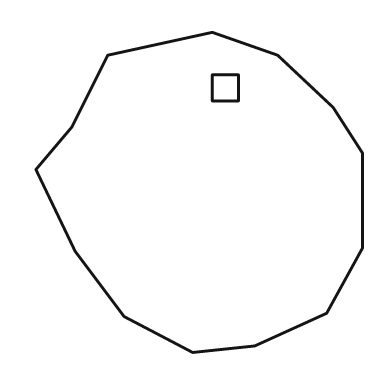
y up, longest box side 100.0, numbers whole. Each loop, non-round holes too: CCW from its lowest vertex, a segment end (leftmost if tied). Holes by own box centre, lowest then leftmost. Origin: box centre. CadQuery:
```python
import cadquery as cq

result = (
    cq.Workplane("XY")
    .moveTo(-2.0, -49.0)
    .lineTo(17.0, -47.0)
    .lineTo(39.0, -37.0)
    .lineTo(50.0, -17.0)
    .lineTo(50.0, 12.0)
    .lineTo(41.0, 26.0)
    .lineTo(24.0, 42.0)
    .lineTo(4.0, 49.0)
    .lineTo(-28.0, 42.0)
    .lineTo(-39.0, 20.0)
    .lineTo(-50.0, 7.0)
    .lineTo(-38.0, -18.0)
    .lineTo(-23.0, -38.0)
    .close()
    .moveTo(4.0, 28.0)
    .lineTo(12.0, 28.0)
    .lineTo(12.0, 36.0)
    .lineTo(4.0, 36.0)
    .close()
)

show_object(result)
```